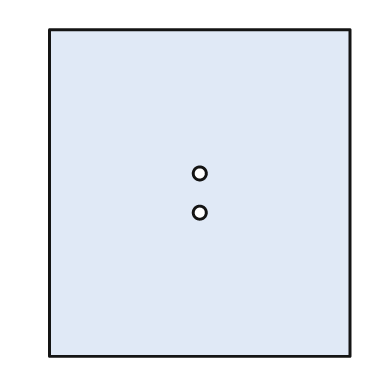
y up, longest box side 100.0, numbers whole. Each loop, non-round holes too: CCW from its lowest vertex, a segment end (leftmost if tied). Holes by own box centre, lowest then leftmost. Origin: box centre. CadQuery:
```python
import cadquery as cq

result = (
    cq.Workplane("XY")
    .moveTo(-46.0, -50.0)
    .lineTo(46.0, -50.0)
    .lineTo(46.0, 50.0)
    .lineTo(-46.0, 50.0)
    .close()
    .moveTo(0.0, -6.0)
    .circle(2.0)
    .moveTo(0.0, 6.0)
    .circle(2.0)
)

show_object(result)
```